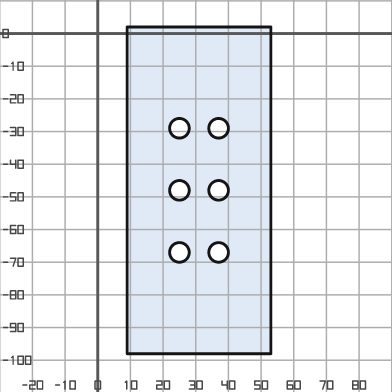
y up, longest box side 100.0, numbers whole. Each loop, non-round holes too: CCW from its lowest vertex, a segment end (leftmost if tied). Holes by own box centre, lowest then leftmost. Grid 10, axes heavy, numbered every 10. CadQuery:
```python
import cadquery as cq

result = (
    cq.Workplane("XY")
    .moveTo(9.0, -98.0)
    .lineTo(53.0, -98.0)
    .lineTo(53.0, 2.0)
    .lineTo(9.0, 2.0)
    .close()
    .moveTo(25.0, -67.0)
    .circle(3.0)
    .moveTo(37.0, -67.0)
    .circle(3.0)
    .moveTo(25.0, -48.0)
    .circle(3.0)
    .moveTo(37.0, -48.0)
    .circle(3.0)
    .moveTo(25.0, -29.0)
    .circle(3.0)
    .moveTo(37.0, -29.0)
    .circle(3.0)
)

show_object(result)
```